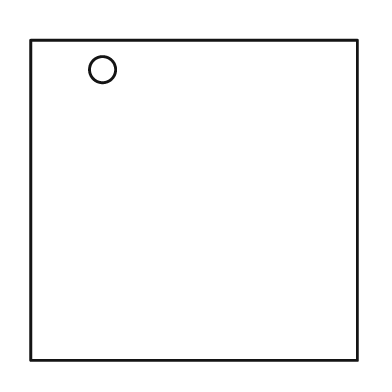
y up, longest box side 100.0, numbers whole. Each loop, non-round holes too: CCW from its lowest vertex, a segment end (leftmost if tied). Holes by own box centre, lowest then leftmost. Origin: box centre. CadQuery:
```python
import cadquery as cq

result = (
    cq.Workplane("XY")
    .moveTo(-50.0, -49.0)
    .lineTo(50.0, -49.0)
    .lineTo(50.0, 49.0)
    .lineTo(-50.0, 49.0)
    .close()
    .moveTo(-28.0, 40.0)
    .circle(4.0)
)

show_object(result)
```